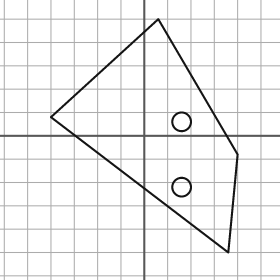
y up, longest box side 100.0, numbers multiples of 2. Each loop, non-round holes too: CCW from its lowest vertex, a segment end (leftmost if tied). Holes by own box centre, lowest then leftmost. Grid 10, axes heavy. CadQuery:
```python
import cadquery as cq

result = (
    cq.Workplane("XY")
    .moveTo(36.0, -50.0)
    .lineTo(40.0, -8.0)
    .lineTo(6.0, 50.0)
    .lineTo(-40.0, 8.0)
    .close()
    .moveTo(16.0, -22.0)
    .circle(4.0)
    .moveTo(16.0, 6.0)
    .circle(4.0)
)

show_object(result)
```